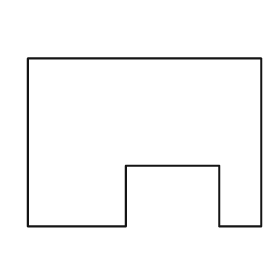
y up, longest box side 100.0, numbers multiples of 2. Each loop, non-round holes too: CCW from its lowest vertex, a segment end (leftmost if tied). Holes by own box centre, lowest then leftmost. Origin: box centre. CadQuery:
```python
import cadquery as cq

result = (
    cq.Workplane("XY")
    .moveTo(-50.0, -36.0)
    .lineTo(-8.0, -36.0)
    .lineTo(-8.0, -10.0)
    .lineTo(32.0, -10.0)
    .lineTo(32.0, -36.0)
    .lineTo(50.0, -36.0)
    .lineTo(50.0, 36.0)
    .lineTo(-50.0, 36.0)
    .close()
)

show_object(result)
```